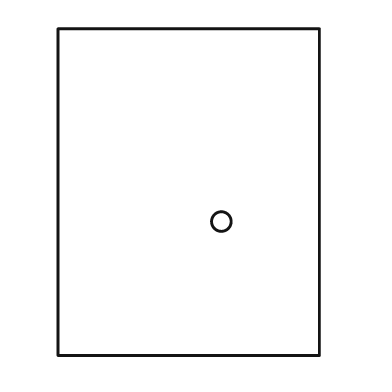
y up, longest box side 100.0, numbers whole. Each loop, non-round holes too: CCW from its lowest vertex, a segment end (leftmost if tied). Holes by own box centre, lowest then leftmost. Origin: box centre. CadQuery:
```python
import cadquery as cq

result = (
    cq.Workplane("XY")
    .moveTo(-40.0, -50.0)
    .lineTo(40.0, -50.0)
    .lineTo(40.0, 50.0)
    .lineTo(-40.0, 50.0)
    .close()
    .moveTo(10.0, -9.0)
    .circle(3.0)
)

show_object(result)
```